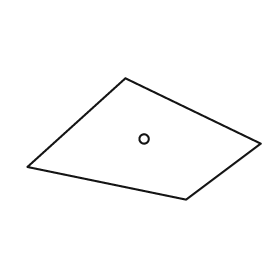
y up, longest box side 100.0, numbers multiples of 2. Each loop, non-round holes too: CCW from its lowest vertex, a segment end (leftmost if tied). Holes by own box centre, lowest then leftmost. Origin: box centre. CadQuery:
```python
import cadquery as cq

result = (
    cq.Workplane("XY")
    .moveTo(18.0, -26.0)
    .lineTo(50.0, -2.0)
    .lineTo(-8.0, 26.0)
    .lineTo(-50.0, -12.0)
    .close()
    .moveTo(0.0, 0.0)
    .circle(2.0)
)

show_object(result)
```